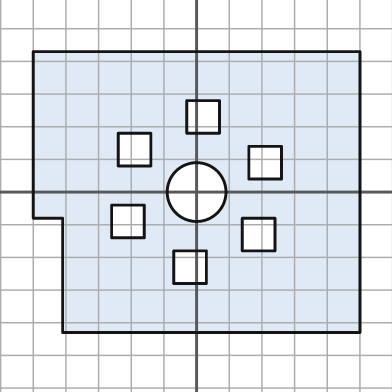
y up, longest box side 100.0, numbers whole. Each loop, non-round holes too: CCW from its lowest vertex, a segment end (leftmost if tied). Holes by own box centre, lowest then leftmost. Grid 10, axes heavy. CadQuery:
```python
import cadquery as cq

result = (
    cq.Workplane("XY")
    .moveTo(-41.0, -43.0)
    .lineTo(50.0, -43.0)
    .lineTo(50.0, 43.0)
    .lineTo(-50.0, 43.0)
    .lineTo(-50.0, -8.0)
    .lineTo(-41.0, -8.0)
    .close()
    .moveTo(-7.0, -28.0)
    .lineTo(3.0, -28.0)
    .lineTo(3.0, -18.0)
    .lineTo(-7.0, -18.0)
    .close()
    .moveTo(14.0, -18.0)
    .lineTo(24.0, -18.0)
    .lineTo(24.0, -8.0)
    .lineTo(14.0, -8.0)
    .close()
    .moveTo(-26.0, -14.0)
    .lineTo(-16.0, -14.0)
    .lineTo(-16.0, -4.0)
    .lineTo(-26.0, -4.0)
    .close()
    .moveTo(0.0, 0.0)
    .circle(9.0)
    .moveTo(16.0, 4.0)
    .lineTo(26.0, 4.0)
    .lineTo(26.0, 14.0)
    .lineTo(16.0, 14.0)
    .close()
    .moveTo(-24.0, 8.0)
    .lineTo(-14.0, 8.0)
    .lineTo(-14.0, 18.0)
    .lineTo(-24.0, 18.0)
    .close()
    .moveTo(-3.0, 18.0)
    .lineTo(7.0, 18.0)
    .lineTo(7.0, 28.0)
    .lineTo(-3.0, 28.0)
    .close()
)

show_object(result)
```